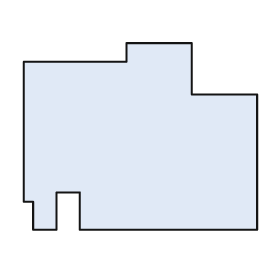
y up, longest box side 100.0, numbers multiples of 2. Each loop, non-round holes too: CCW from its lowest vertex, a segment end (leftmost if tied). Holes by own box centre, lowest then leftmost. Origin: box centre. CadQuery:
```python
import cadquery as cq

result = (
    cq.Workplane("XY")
    .moveTo(-46.0, -40.0)
    .lineTo(-36.0, -40.0)
    .lineTo(-36.0, -24.0)
    .lineTo(-26.0, -24.0)
    .lineTo(-26.0, -40.0)
    .lineTo(50.0, -40.0)
    .lineTo(50.0, 18.0)
    .lineTo(22.0, 18.0)
    .lineTo(22.0, 40.0)
    .lineTo(-6.0, 40.0)
    .lineTo(-6.0, 32.0)
    .lineTo(-50.0, 32.0)
    .lineTo(-50.0, -28.0)
    .lineTo(-46.0, -28.0)
    .close()
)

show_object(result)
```